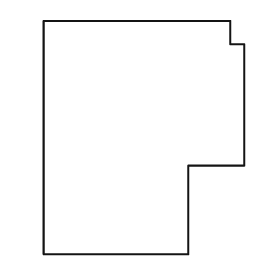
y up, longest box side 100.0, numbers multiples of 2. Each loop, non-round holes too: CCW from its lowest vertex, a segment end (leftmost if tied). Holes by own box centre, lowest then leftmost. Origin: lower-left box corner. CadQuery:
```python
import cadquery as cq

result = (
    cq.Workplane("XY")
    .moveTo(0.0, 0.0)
    .lineTo(62.0, 0.0)
    .lineTo(62.0, 38.0)
    .lineTo(86.0, 38.0)
    .lineTo(86.0, 90.0)
    .lineTo(80.0, 90.0)
    .lineTo(80.0, 100.0)
    .lineTo(0.0, 100.0)
    .close()
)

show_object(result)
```